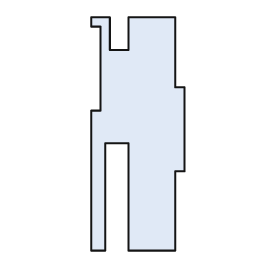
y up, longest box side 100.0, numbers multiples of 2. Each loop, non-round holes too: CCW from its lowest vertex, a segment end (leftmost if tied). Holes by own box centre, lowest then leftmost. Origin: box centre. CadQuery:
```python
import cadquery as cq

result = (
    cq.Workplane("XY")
    .moveTo(-20.0, -50.0)
    .lineTo(-14.0, -50.0)
    .lineTo(-14.0, -4.0)
    .lineTo(-4.0, -4.0)
    .lineTo(-4.0, -50.0)
    .lineTo(16.0, -50.0)
    .lineTo(16.0, -16.0)
    .lineTo(20.0, -16.0)
    .lineTo(20.0, 20.0)
    .lineTo(16.0, 20.0)
    .lineTo(16.0, 50.0)
    .lineTo(-4.0, 50.0)
    .lineTo(-4.0, 36.0)
    .lineTo(-12.0, 36.0)
    .lineTo(-12.0, 50.0)
    .lineTo(-20.0, 50.0)
    .lineTo(-20.0, 46.0)
    .lineTo(-16.0, 46.0)
    .lineTo(-16.0, 10.0)
    .lineTo(-20.0, 10.0)
    .close()
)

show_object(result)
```